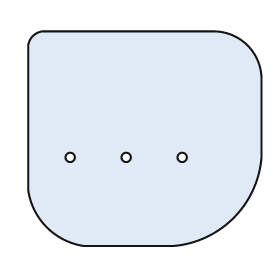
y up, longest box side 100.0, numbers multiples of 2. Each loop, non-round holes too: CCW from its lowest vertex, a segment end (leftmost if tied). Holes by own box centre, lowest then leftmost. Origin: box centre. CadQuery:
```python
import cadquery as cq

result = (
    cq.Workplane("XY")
    .moveTo(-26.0, -46.0)
    .lineTo(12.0, -46.0)
    .threePointArc((38.0, -34.0), (50.0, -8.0))
    .lineTo(50.0, 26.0)
    .threePointArc((44.0, 40.0), (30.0, 46.0))
    .lineTo(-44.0, 46.0)
    .threePointArc((-48.0, 44.0), (-50.0, 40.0))
    .lineTo(-50.0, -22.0)
    .threePointArc((-42.0, -38.0), (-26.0, -46.0))
    .close()
    .moveTo(-32.0, -8.0)
    .circle(2.0)
    .moveTo(-8.0, -8.0)
    .circle(2.0)
    .moveTo(16.0, -8.0)
    .circle(2.0)
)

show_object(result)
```